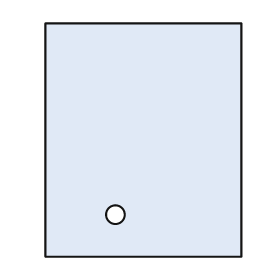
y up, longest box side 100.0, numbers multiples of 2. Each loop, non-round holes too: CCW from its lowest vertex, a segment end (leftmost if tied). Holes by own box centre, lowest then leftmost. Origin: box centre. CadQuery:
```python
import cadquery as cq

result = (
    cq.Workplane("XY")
    .moveTo(-42.0, -50.0)
    .lineTo(42.0, -50.0)
    .lineTo(42.0, 50.0)
    .lineTo(-42.0, 50.0)
    .close()
    .moveTo(-12.0, -32.0)
    .circle(4.0)
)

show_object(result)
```